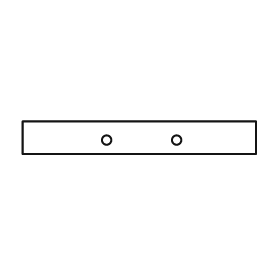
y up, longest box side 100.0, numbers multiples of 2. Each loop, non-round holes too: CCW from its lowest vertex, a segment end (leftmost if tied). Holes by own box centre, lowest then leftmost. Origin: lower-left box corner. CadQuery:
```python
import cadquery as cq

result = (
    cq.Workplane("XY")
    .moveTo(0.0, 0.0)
    .lineTo(100.0, 0.0)
    .lineTo(100.0, 14.0)
    .lineTo(0.0, 14.0)
    .close()
    .moveTo(36.0, 6.0)
    .circle(2.0)
    .moveTo(66.0, 6.0)
    .circle(2.0)
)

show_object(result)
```